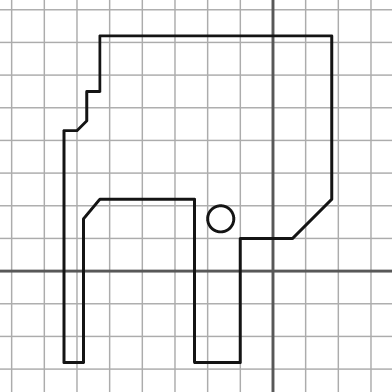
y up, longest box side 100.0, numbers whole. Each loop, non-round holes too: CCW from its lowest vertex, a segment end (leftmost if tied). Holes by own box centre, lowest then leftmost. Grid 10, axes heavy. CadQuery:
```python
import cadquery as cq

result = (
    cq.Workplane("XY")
    .moveTo(-64.0, -28.0)
    .lineTo(-58.0, -28.0)
    .lineTo(-58.0, 16.0)
    .lineTo(-53.0, 22.0)
    .lineTo(-24.0, 22.0)
    .lineTo(-24.0, -28.0)
    .lineTo(-10.0, -28.0)
    .lineTo(-10.0, 10.0)
    .lineTo(6.0, 10.0)
    .lineTo(18.0, 22.0)
    .lineTo(18.0, 72.0)
    .lineTo(-53.0, 72.0)
    .lineTo(-53.0, 55.0)
    .lineTo(-57.0, 55.0)
    .lineTo(-57.0, 46.0)
    .lineTo(-60.0, 43.0)
    .lineTo(-64.0, 43.0)
    .close()
    .moveTo(-16.0, 16.0)
    .circle(4.0)
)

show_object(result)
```